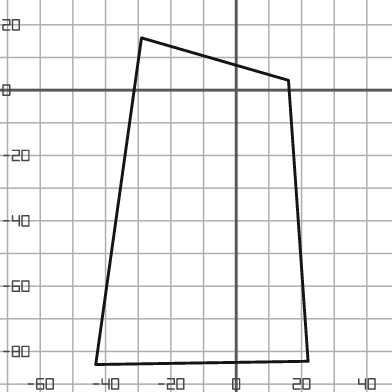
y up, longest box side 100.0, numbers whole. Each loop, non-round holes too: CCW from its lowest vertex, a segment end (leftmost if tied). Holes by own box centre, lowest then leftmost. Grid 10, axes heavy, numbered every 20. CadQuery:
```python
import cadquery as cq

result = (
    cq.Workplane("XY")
    .moveTo(-43.0, -84.0)
    .lineTo(22.0, -83.0)
    .lineTo(16.0, 3.0)
    .lineTo(-29.0, 16.0)
    .close()
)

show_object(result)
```